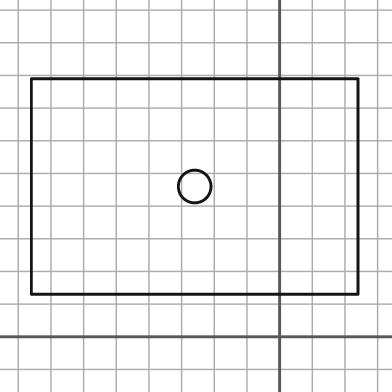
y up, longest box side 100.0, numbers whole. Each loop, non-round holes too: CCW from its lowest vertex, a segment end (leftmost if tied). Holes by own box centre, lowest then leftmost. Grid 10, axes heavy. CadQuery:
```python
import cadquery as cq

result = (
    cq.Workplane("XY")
    .moveTo(-76.0, 13.0)
    .lineTo(24.0, 13.0)
    .lineTo(24.0, 79.0)
    .lineTo(-76.0, 79.0)
    .close()
    .moveTo(-26.0, 46.0)
    .circle(5.0)
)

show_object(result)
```